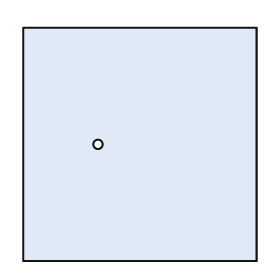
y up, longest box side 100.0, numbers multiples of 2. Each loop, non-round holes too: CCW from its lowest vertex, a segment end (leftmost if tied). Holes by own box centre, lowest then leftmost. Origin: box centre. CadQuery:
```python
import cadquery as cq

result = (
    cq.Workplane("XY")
    .moveTo(-50.0, -50.0)
    .lineTo(50.0, -50.0)
    .lineTo(50.0, 50.0)
    .lineTo(-50.0, 50.0)
    .close()
    .moveTo(-18.0, 0.0)
    .circle(2.0)
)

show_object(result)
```